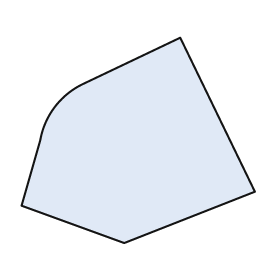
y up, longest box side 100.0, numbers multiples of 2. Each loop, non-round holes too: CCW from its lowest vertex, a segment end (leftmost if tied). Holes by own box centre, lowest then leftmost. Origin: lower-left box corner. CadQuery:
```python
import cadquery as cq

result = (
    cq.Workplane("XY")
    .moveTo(44.0, 0.0)
    .lineTo(100.0, 22.0)
    .lineTo(68.0, 88.0)
    .lineTo(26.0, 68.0)
    .threePointArc((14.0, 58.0), (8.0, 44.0))
    .lineTo(0.0, 16.0)
    .close()
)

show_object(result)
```